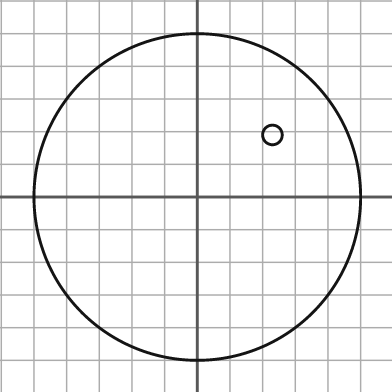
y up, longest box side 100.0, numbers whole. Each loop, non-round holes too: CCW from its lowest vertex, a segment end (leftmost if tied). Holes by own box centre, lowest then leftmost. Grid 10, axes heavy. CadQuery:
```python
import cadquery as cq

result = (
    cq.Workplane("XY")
    .moveTo(0.0, 0.0)
    .circle(50.0)
    .moveTo(23.0, 19.0)
    .circle(3.0)
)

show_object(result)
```